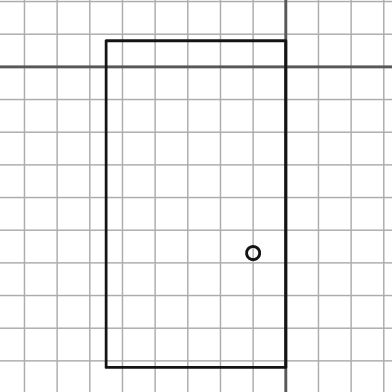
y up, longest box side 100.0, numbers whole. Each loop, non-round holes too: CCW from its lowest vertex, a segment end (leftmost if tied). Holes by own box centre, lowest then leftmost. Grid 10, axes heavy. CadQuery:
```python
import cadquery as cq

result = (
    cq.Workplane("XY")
    .moveTo(-55.0, -92.0)
    .lineTo(0.0, -92.0)
    .lineTo(0.0, 8.0)
    .lineTo(-55.0, 8.0)
    .close()
    .moveTo(-10.0, -57.0)
    .circle(2.0)
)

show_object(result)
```